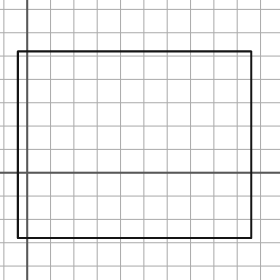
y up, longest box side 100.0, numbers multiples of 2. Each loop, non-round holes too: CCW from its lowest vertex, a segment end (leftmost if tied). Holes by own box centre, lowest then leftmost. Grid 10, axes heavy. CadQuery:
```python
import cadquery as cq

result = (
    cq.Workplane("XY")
    .moveTo(-4.0, -28.0)
    .lineTo(96.0, -28.0)
    .lineTo(96.0, 52.0)
    .lineTo(-4.0, 52.0)
    .close()
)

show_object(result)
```